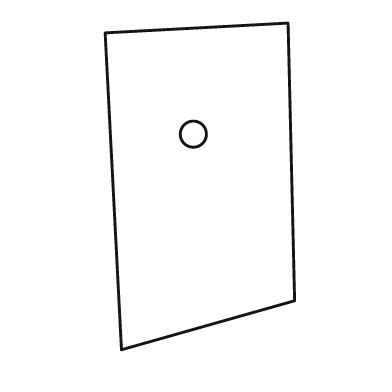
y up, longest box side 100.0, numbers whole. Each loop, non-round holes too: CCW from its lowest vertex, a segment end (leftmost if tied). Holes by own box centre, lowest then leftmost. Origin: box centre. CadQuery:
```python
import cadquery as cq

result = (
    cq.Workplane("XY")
    .moveTo(-24.0, -50.0)
    .lineTo(29.0, -35.0)
    .lineTo(27.0, 50.0)
    .lineTo(-29.0, 47.0)
    .close()
    .moveTo(-2.0, 16.0)
    .circle(4.0)
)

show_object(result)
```